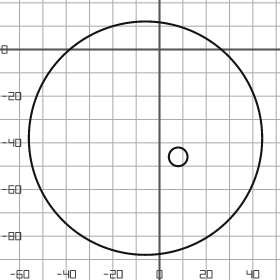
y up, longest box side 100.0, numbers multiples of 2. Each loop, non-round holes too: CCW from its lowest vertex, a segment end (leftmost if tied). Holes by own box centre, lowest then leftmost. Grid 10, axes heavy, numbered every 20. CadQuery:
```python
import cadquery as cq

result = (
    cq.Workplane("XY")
    .moveTo(-6.0, -38.0)
    .circle(50.0)
    .moveTo(8.0, -46.0)
    .circle(4.0)
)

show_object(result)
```